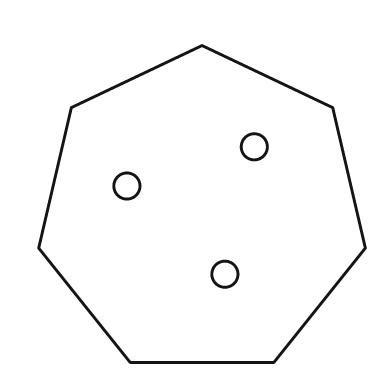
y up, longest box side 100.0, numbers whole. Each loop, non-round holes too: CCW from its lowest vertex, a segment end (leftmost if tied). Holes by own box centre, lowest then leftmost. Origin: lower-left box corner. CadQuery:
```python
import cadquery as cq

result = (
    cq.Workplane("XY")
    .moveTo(28.0, 0.0)
    .lineTo(72.0, 0.0)
    .lineTo(100.0, 35.0)
    .lineTo(90.0, 78.0)
    .lineTo(50.0, 97.0)
    .lineTo(10.0, 78.0)
    .lineTo(0.0, 35.0)
    .close()
    .moveTo(57.0, 27.0)
    .circle(4.0)
    .moveTo(27.0, 54.0)
    .circle(4.0)
    .moveTo(66.0, 66.0)
    .circle(4.0)
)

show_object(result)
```